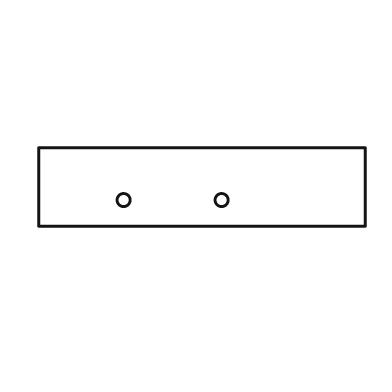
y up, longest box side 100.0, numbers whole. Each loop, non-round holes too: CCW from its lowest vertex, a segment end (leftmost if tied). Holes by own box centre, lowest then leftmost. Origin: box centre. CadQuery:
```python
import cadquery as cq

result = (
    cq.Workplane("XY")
    .moveTo(-50.0, -12.0)
    .lineTo(50.0, -12.0)
    .lineTo(50.0, 12.0)
    .lineTo(-50.0, 12.0)
    .close()
    .moveTo(-24.0, -4.0)
    .circle(2.0)
    .moveTo(6.0, -4.0)
    .circle(2.0)
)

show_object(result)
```